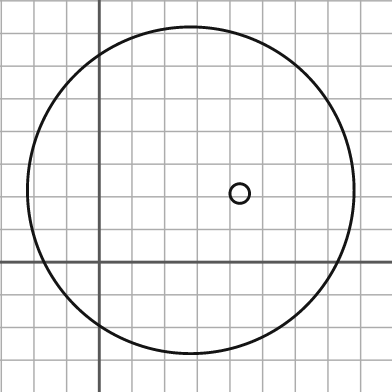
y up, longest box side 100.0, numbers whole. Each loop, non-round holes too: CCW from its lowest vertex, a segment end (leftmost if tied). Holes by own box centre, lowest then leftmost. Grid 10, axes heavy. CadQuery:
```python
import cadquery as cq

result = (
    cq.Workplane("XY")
    .moveTo(28.0, 22.0)
    .circle(50.0)
    .moveTo(43.0, 21.0)
    .circle(3.0)
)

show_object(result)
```